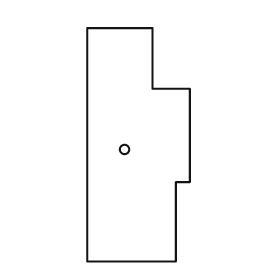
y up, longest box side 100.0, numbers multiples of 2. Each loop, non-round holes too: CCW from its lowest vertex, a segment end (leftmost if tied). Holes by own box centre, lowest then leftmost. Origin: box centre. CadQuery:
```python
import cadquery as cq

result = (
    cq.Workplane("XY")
    .moveTo(-22.0, -50.0)
    .lineTo(16.0, -50.0)
    .lineTo(16.0, -16.0)
    .lineTo(22.0, -16.0)
    .lineTo(22.0, 24.0)
    .lineTo(6.0, 24.0)
    .lineTo(6.0, 50.0)
    .lineTo(-22.0, 50.0)
    .close()
    .moveTo(-6.0, -2.0)
    .circle(2.0)
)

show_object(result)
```